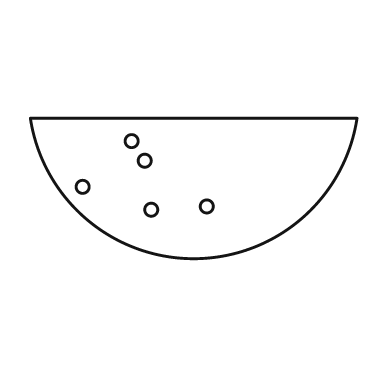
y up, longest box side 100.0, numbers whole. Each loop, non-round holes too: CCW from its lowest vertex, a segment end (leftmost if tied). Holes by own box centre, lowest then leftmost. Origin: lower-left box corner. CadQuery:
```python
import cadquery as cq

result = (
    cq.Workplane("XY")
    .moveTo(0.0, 43.0)
    .threePointArc((50.0, 0.0), (100.0, 43.0))
    .close()
    .moveTo(37.0, 15.0)
    .circle(2.0)
    .moveTo(54.0, 16.0)
    .circle(2.0)
    .moveTo(16.0, 22.0)
    .circle(2.0)
    .moveTo(35.0, 30.0)
    .circle(2.0)
    .moveTo(31.0, 36.0)
    .circle(2.0)
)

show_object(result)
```